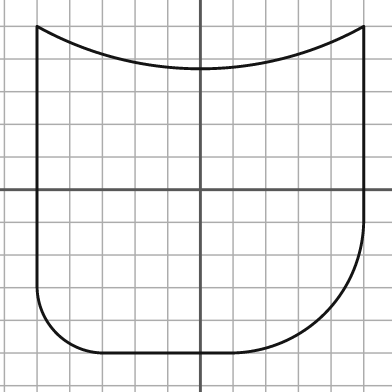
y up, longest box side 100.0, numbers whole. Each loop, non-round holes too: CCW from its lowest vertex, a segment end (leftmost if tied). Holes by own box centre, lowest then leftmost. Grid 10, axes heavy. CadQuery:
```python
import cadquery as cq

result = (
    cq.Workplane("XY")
    .moveTo(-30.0, -50.0)
    .lineTo(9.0, -50.0)
    .threePointArc((38.0, -38.0), (50.0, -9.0))
    .lineTo(50.0, 50.0)
    .threePointArc((0.0, 37.0), (-50.0, 50.0))
    .lineTo(-50.0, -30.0)
    .threePointArc((-44.0, -44.0), (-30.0, -50.0))
    .close()
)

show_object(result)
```